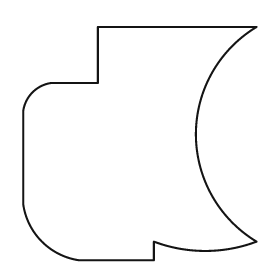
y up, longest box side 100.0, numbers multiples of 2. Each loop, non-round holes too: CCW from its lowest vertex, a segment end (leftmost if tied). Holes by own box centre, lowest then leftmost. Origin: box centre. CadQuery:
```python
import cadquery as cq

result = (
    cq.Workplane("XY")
    .moveTo(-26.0, -50.0)
    .lineTo(6.0, -50.0)
    .lineTo(6.0, -42.0)
    .threePointArc((28.0, -46.0), (50.0, -42.0))
    .threePointArc((24.0, 4.0), (50.0, 50.0))
    .lineTo(-18.0, 50.0)
    .lineTo(-18.0, 26.0)
    .lineTo(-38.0, 26.0)
    .threePointArc((-46.0, 22.0), (-50.0, 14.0))
    .lineTo(-50.0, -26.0)
    .threePointArc((-42.0, -42.0), (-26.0, -50.0))
    .close()
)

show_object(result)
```